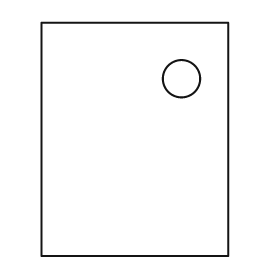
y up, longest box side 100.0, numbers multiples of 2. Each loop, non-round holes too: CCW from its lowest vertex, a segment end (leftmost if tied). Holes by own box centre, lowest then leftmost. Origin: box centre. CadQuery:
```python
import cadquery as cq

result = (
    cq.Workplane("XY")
    .moveTo(-40.0, -50.0)
    .lineTo(40.0, -50.0)
    .lineTo(40.0, 50.0)
    .lineTo(-40.0, 50.0)
    .close()
    .moveTo(20.0, 26.0)
    .circle(8.0)
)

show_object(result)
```